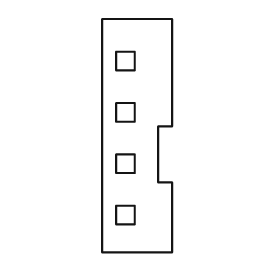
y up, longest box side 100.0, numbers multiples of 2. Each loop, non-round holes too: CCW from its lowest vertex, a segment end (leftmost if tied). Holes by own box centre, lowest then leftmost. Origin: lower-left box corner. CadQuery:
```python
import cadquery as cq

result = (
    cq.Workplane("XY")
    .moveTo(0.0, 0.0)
    .lineTo(30.0, 0.0)
    .lineTo(30.0, 30.0)
    .lineTo(24.0, 30.0)
    .lineTo(24.0, 54.0)
    .lineTo(30.0, 54.0)
    .lineTo(30.0, 100.0)
    .lineTo(0.0, 100.0)
    .close()
    .moveTo(6.0, 12.0)
    .lineTo(14.0, 12.0)
    .lineTo(14.0, 20.0)
    .lineTo(6.0, 20.0)
    .close()
    .moveTo(6.0, 34.0)
    .lineTo(14.0, 34.0)
    .lineTo(14.0, 42.0)
    .lineTo(6.0, 42.0)
    .close()
    .moveTo(6.0, 56.0)
    .lineTo(14.0, 56.0)
    .lineTo(14.0, 64.0)
    .lineTo(6.0, 64.0)
    .close()
    .moveTo(6.0, 78.0)
    .lineTo(14.0, 78.0)
    .lineTo(14.0, 86.0)
    .lineTo(6.0, 86.0)
    .close()
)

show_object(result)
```